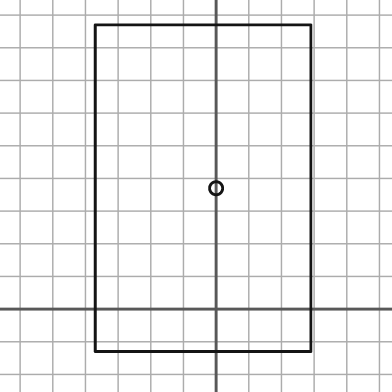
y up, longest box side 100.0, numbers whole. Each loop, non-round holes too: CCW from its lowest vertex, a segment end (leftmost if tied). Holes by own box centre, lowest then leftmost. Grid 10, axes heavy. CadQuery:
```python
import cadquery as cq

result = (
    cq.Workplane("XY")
    .moveTo(-37.0, -13.0)
    .lineTo(29.0, -13.0)
    .lineTo(29.0, 87.0)
    .lineTo(-37.0, 87.0)
    .close()
    .moveTo(0.0, 37.0)
    .circle(2.0)
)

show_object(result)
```